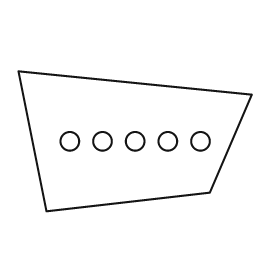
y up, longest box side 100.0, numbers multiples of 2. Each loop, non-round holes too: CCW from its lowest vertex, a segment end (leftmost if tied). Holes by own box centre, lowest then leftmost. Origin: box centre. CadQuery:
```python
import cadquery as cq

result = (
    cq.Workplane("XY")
    .moveTo(-38.0, -30.0)
    .lineTo(32.0, -22.0)
    .lineTo(50.0, 20.0)
    .lineTo(-50.0, 30.0)
    .close()
    .moveTo(-28.0, 0.0)
    .circle(4.0)
    .moveTo(-14.0, 0.0)
    .circle(4.0)
    .moveTo(0.0, 0.0)
    .circle(4.0)
    .moveTo(14.0, 0.0)
    .circle(4.0)
    .moveTo(28.0, 0.0)
    .circle(4.0)
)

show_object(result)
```